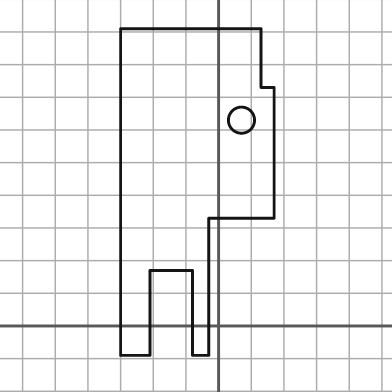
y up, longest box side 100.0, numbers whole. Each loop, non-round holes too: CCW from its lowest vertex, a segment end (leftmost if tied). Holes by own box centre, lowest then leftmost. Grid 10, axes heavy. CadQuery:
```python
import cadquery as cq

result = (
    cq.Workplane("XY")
    .moveTo(-30.0, -9.0)
    .lineTo(-21.0, -9.0)
    .lineTo(-21.0, 17.0)
    .lineTo(-8.0, 17.0)
    .lineTo(-8.0, -9.0)
    .lineTo(-3.0, -9.0)
    .lineTo(-3.0, 33.0)
    .lineTo(17.0, 33.0)
    .lineTo(17.0, 73.0)
    .lineTo(13.0, 73.0)
    .lineTo(13.0, 91.0)
    .lineTo(-30.0, 91.0)
    .close()
    .moveTo(7.0, 63.0)
    .circle(4.0)
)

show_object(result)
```